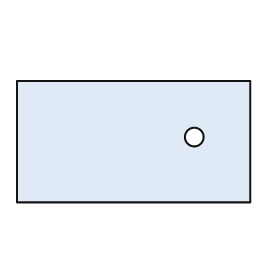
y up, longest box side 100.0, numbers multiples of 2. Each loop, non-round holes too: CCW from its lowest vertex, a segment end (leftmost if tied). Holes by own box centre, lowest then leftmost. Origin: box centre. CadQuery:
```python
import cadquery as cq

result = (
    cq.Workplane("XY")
    .moveTo(-50.0, -26.0)
    .lineTo(50.0, -26.0)
    .lineTo(50.0, 26.0)
    .lineTo(-50.0, 26.0)
    .close()
    .moveTo(26.0, 2.0)
    .circle(4.0)
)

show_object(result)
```